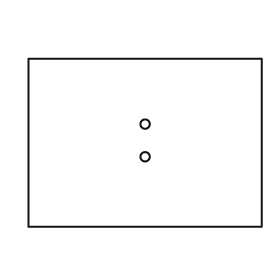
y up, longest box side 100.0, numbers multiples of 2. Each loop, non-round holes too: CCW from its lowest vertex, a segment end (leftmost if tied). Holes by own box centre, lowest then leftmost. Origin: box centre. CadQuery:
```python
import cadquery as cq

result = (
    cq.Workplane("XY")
    .moveTo(-50.0, -36.0)
    .lineTo(50.0, -36.0)
    .lineTo(50.0, 36.0)
    .lineTo(-50.0, 36.0)
    .close()
    .moveTo(0.0, -6.0)
    .circle(2.0)
    .moveTo(0.0, 8.0)
    .circle(2.0)
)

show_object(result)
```